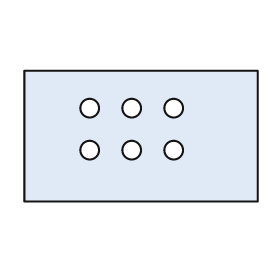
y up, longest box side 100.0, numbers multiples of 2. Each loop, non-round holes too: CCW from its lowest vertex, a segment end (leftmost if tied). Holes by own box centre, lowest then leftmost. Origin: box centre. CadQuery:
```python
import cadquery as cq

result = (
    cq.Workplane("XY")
    .moveTo(-50.0, -28.0)
    .lineTo(50.0, -28.0)
    .lineTo(50.0, 28.0)
    .lineTo(-50.0, 28.0)
    .close()
    .moveTo(-22.0, -6.0)
    .circle(4.0)
    .moveTo(-4.0, -6.0)
    .circle(4.0)
    .moveTo(14.0, -6.0)
    .circle(4.0)
    .moveTo(-22.0, 12.0)
    .circle(4.0)
    .moveTo(-4.0, 12.0)
    .circle(4.0)
    .moveTo(14.0, 12.0)
    .circle(4.0)
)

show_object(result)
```